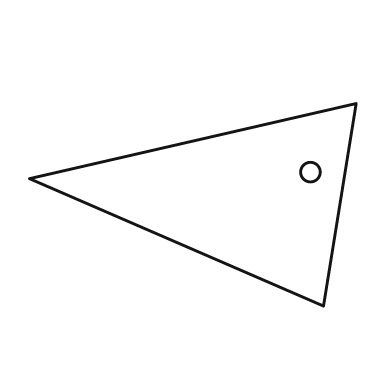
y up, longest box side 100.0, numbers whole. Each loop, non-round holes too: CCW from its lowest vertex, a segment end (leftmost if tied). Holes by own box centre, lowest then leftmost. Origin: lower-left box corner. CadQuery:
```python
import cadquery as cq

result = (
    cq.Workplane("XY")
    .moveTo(90.0, 0.0)
    .lineTo(100.0, 62.0)
    .lineTo(0.0, 39.0)
    .close()
    .moveTo(86.0, 41.0)
    .circle(3.0)
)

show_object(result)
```